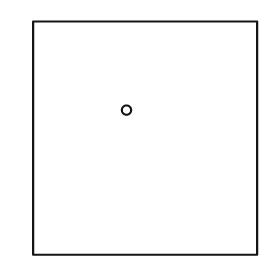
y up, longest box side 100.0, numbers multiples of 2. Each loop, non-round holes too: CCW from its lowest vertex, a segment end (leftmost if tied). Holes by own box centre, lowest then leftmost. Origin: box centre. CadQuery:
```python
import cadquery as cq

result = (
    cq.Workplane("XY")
    .moveTo(-48.0, -50.0)
    .lineTo(48.0, -50.0)
    .lineTo(48.0, 50.0)
    .lineTo(-48.0, 50.0)
    .close()
    .moveTo(-8.0, 12.0)
    .circle(2.0)
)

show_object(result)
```